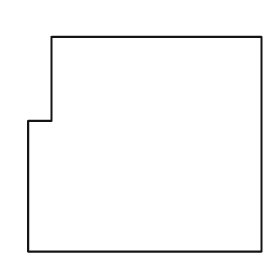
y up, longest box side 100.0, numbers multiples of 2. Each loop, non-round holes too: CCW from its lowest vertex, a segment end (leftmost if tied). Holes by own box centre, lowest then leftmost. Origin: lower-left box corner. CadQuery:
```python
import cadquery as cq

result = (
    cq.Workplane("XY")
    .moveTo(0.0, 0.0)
    .lineTo(100.0, 0.0)
    .lineTo(100.0, 92.0)
    .lineTo(10.0, 92.0)
    .lineTo(10.0, 56.0)
    .lineTo(0.0, 56.0)
    .close()
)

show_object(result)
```